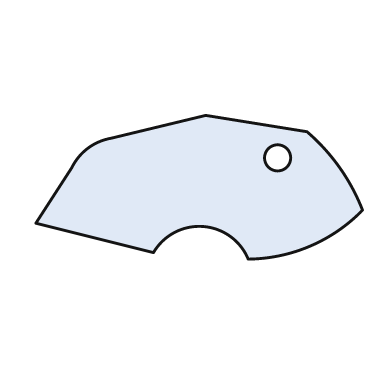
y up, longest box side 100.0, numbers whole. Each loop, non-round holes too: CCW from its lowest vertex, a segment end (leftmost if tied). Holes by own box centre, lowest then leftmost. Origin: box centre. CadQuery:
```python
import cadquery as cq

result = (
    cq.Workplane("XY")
    .moveTo(15.0, -22.0)
    .threePointArc((34.0, -18.0), (50.0, -7.0))
    .threePointArc((43.0, 6.0), (33.0, 17.0))
    .lineTo(2.0, 22.0)
    .lineTo(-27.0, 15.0)
    .threePointArc((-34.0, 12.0), (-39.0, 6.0))
    .lineTo(-50.0, -11.0)
    .lineTo(-14.0, -20.0)
    .threePointArc((1.0, -12.0), (15.0, -22.0))
    .close()
    .moveTo(24.0, 9.0)
    .circle(4.0)
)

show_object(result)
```